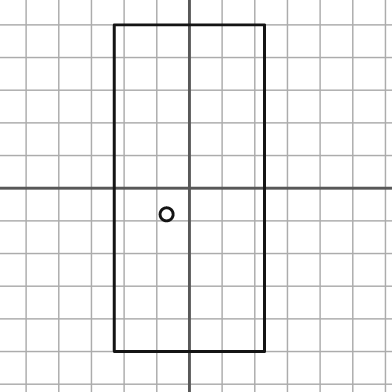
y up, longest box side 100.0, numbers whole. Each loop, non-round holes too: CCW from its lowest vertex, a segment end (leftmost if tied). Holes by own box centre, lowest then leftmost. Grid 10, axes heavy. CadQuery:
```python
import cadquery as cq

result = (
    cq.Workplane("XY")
    .moveTo(-23.0, -50.0)
    .lineTo(23.0, -50.0)
    .lineTo(23.0, 50.0)
    .lineTo(-23.0, 50.0)
    .close()
    .moveTo(-7.0, -8.0)
    .circle(2.0)
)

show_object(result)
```